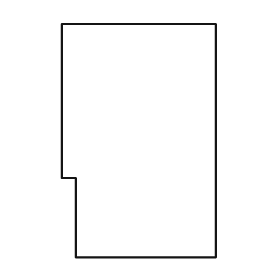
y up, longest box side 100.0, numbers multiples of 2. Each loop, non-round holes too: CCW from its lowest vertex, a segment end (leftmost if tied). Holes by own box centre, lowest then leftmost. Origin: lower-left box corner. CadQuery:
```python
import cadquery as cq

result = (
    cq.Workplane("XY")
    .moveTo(6.0, 0.0)
    .lineTo(66.0, 0.0)
    .lineTo(66.0, 100.0)
    .lineTo(0.0, 100.0)
    .lineTo(0.0, 34.0)
    .lineTo(6.0, 34.0)
    .close()
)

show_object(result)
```